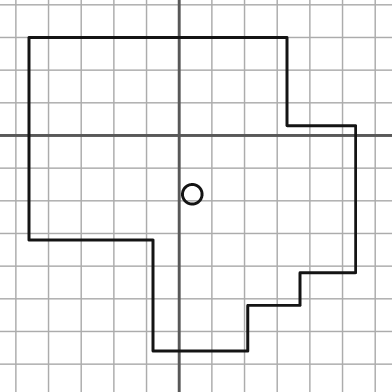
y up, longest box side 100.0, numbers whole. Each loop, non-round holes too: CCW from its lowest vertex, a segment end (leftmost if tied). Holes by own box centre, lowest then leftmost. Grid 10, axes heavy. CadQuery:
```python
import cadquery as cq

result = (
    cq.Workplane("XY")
    .moveTo(-8.0, -66.0)
    .lineTo(21.0, -66.0)
    .lineTo(21.0, -52.0)
    .lineTo(37.0, -52.0)
    .lineTo(37.0, -42.0)
    .lineTo(54.0, -42.0)
    .lineTo(54.0, 3.0)
    .lineTo(33.0, 3.0)
    .lineTo(33.0, 30.0)
    .lineTo(-46.0, 30.0)
    .lineTo(-46.0, -32.0)
    .lineTo(-8.0, -32.0)
    .close()
    .moveTo(4.0, -18.0)
    .circle(3.0)
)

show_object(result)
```